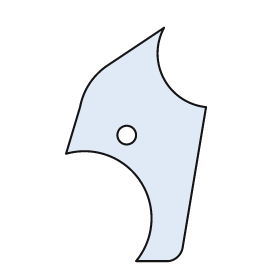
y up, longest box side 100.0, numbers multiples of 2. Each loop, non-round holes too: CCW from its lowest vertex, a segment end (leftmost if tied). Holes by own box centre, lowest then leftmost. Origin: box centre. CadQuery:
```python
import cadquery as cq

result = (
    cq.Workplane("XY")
    .moveTo(0.0, -50.0)
    .lineTo(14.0, -50.0)
    .threePointArc((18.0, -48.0), (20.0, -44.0))
    .lineTo(30.0, 16.0)
    .threePointArc((12.0, 28.0), (12.0, 50.0))
    .lineTo(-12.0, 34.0)
    .threePointArc((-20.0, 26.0), (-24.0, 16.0))
    .lineTo(-30.0, -4.0)
    .threePointArc((2.0, -16.0), (0.0, -50.0))
    .close()
    .moveTo(-4.0, 4.0)
    .circle(4.0)
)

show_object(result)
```